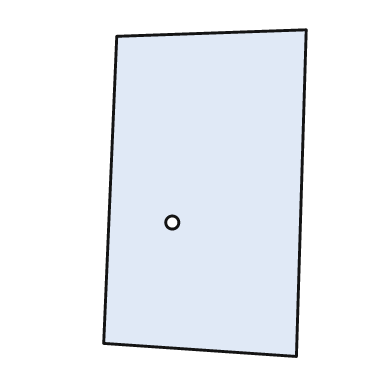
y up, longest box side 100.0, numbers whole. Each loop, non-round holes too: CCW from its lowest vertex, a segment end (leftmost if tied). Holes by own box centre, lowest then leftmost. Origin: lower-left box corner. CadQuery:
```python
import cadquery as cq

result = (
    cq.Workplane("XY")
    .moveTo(59.0, 0.0)
    .lineTo(62.0, 100.0)
    .lineTo(4.0, 98.0)
    .lineTo(0.0, 4.0)
    .close()
    .moveTo(21.0, 41.0)
    .circle(2.0)
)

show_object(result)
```